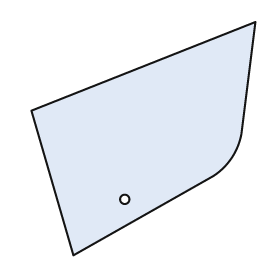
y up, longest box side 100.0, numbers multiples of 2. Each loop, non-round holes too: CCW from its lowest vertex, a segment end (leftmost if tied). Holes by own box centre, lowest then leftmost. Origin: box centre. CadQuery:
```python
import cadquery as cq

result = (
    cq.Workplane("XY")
    .moveTo(-30.0, -50.0)
    .lineTo(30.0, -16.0)
    .threePointArc((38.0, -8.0), (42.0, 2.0))
    .lineTo(48.0, 50.0)
    .lineTo(-48.0, 12.0)
    .close()
    .moveTo(-8.0, -26.0)
    .circle(2.0)
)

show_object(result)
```